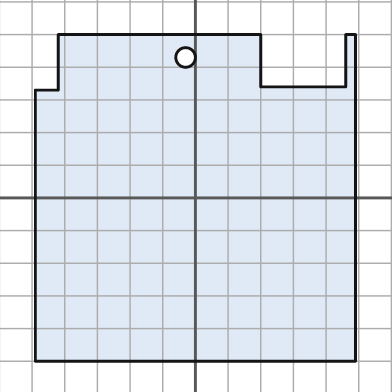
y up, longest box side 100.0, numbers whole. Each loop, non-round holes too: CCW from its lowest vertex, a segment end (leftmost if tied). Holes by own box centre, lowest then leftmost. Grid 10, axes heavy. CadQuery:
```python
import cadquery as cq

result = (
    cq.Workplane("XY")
    .moveTo(-49.0, -50.0)
    .lineTo(49.0, -50.0)
    .lineTo(49.0, 50.0)
    .lineTo(46.0, 50.0)
    .lineTo(46.0, 34.0)
    .lineTo(20.0, 34.0)
    .lineTo(20.0, 50.0)
    .lineTo(-42.0, 50.0)
    .lineTo(-42.0, 33.0)
    .lineTo(-49.0, 33.0)
    .close()
    .moveTo(-3.0, 43.0)
    .circle(3.0)
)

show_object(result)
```